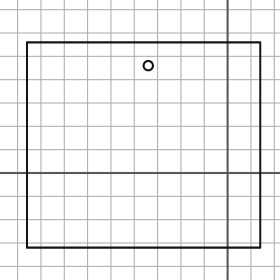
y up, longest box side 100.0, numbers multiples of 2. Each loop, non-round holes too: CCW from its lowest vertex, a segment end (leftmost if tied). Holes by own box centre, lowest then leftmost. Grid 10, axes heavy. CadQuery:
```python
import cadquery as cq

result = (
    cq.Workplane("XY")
    .moveTo(-86.0, -32.0)
    .lineTo(14.0, -32.0)
    .lineTo(14.0, 56.0)
    .lineTo(-86.0, 56.0)
    .close()
    .moveTo(-34.0, 46.0)
    .circle(2.0)
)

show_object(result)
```